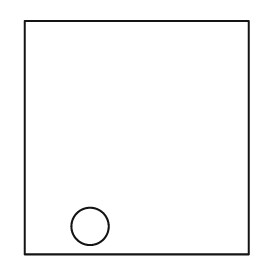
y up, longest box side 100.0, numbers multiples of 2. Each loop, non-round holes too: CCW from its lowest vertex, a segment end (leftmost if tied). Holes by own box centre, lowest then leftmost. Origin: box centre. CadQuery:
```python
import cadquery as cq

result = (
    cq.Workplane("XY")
    .moveTo(-48.0, -50.0)
    .lineTo(48.0, -50.0)
    .lineTo(48.0, 50.0)
    .lineTo(-48.0, 50.0)
    .close()
    .moveTo(-20.0, -38.0)
    .circle(8.0)
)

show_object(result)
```